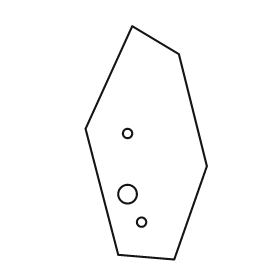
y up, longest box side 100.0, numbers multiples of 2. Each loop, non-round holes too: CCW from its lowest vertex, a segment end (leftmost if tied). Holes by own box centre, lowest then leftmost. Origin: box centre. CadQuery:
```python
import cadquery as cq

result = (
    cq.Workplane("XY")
    .moveTo(12.0, -50.0)
    .lineTo(26.0, -10.0)
    .lineTo(14.0, 38.0)
    .lineTo(-6.0, 50.0)
    .lineTo(-26.0, 6.0)
    .lineTo(-12.0, -48.0)
    .close()
    .moveTo(-2.0, -34.0)
    .circle(2.0)
    .moveTo(-8.0, -22.0)
    .circle(4.0)
    .moveTo(-8.0, 4.0)
    .circle(2.0)
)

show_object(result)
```